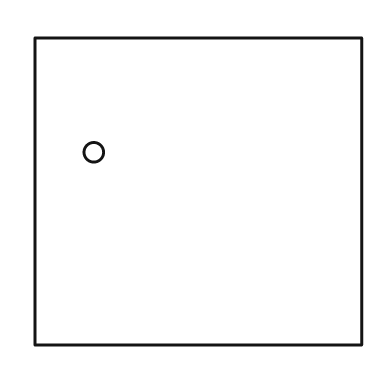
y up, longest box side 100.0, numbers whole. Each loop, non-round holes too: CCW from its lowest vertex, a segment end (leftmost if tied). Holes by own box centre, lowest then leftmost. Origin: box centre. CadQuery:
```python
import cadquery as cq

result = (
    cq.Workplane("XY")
    .moveTo(-50.0, -47.0)
    .lineTo(50.0, -47.0)
    .lineTo(50.0, 47.0)
    .lineTo(-50.0, 47.0)
    .close()
    .moveTo(-32.0, 12.0)
    .circle(3.0)
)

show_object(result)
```